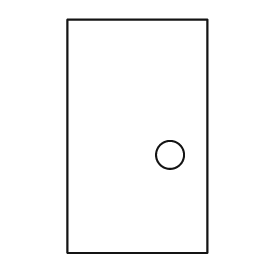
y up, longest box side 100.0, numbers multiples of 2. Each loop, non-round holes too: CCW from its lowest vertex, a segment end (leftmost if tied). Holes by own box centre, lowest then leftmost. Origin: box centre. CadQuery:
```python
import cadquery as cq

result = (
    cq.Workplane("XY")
    .moveTo(-30.0, -50.0)
    .lineTo(30.0, -50.0)
    .lineTo(30.0, 50.0)
    .lineTo(-30.0, 50.0)
    .close()
    .moveTo(14.0, -8.0)
    .circle(6.0)
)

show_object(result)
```